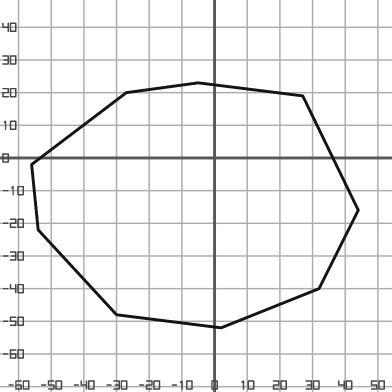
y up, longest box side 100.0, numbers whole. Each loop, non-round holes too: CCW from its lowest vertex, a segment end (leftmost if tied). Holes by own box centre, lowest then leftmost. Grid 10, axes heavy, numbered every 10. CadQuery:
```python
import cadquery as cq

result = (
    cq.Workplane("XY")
    .moveTo(2.0, -52.0)
    .lineTo(32.0, -40.0)
    .lineTo(44.0, -16.0)
    .lineTo(27.0, 19.0)
    .lineTo(-5.0, 23.0)
    .lineTo(-27.0, 20.0)
    .lineTo(-56.0, -2.0)
    .lineTo(-54.0, -22.0)
    .lineTo(-30.0, -48.0)
    .close()
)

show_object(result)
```